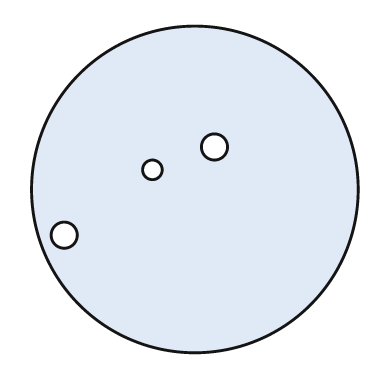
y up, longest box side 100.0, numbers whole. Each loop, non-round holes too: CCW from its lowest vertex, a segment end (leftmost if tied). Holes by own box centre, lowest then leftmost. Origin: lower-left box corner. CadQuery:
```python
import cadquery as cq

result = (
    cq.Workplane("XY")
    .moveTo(50.0, 50.0)
    .circle(50.0)
    .moveTo(10.0, 36.0)
    .circle(4.0)
    .moveTo(37.0, 56.0)
    .circle(3.0)
    .moveTo(56.0, 63.0)
    .circle(4.0)
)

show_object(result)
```